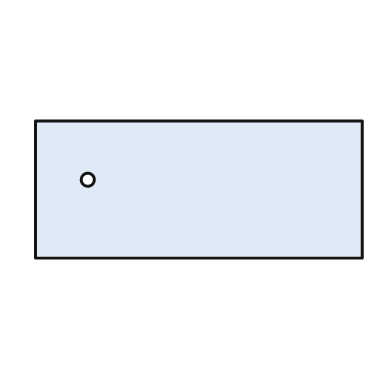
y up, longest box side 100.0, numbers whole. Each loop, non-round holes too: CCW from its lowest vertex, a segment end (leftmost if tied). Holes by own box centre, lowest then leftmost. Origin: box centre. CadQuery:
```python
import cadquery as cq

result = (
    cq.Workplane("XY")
    .moveTo(-50.0, -21.0)
    .lineTo(50.0, -21.0)
    .lineTo(50.0, 21.0)
    .lineTo(-50.0, 21.0)
    .close()
    .moveTo(-34.0, 3.0)
    .circle(2.0)
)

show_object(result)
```